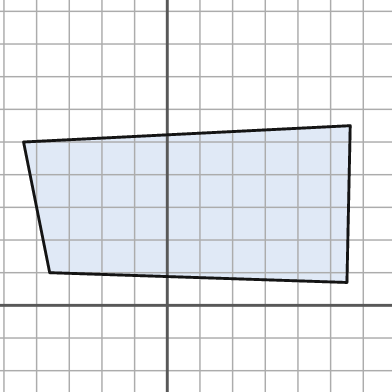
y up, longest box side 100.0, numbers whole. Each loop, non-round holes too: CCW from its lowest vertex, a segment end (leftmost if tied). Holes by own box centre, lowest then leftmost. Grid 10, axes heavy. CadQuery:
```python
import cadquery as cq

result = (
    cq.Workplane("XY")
    .moveTo(55.0, 7.0)
    .lineTo(56.0, 55.0)
    .lineTo(-44.0, 50.0)
    .lineTo(-36.0, 10.0)
    .close()
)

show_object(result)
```